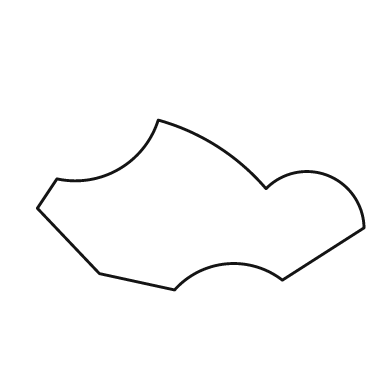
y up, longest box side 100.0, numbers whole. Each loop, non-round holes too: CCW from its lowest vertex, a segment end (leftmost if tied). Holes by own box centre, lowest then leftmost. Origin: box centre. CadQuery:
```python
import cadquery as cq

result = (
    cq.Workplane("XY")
    .moveTo(-8.0, -26.0)
    .threePointArc((8.0, -18.0), (25.0, -23.0))
    .lineTo(50.0, -7.0)
    .threePointArc((39.0, 9.0), (20.0, 5.0))
    .threePointArc((5.0, 18.0), (-13.0, 26.0))
    .threePointArc((-25.0, 11.0), (-44.0, 8.0))
    .lineTo(-50.0, -1.0)
    .lineTo(-31.0, -21.0)
    .close()
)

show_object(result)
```